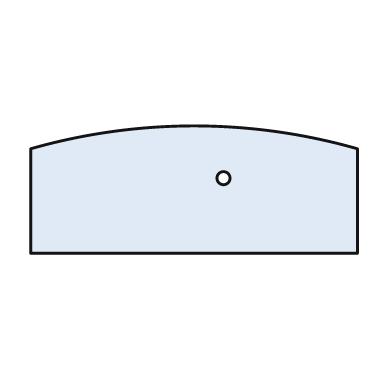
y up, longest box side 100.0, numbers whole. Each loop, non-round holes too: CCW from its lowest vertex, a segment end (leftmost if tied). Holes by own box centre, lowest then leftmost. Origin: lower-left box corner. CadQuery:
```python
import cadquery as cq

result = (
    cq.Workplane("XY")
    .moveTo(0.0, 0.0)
    .lineTo(100.0, 0.0)
    .lineTo(100.0, 32.0)
    .threePointArc((50.0, 39.0), (0.0, 32.0))
    .close()
    .moveTo(59.0, 23.0)
    .circle(2.0)
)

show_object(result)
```